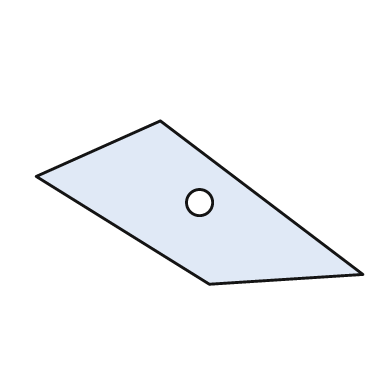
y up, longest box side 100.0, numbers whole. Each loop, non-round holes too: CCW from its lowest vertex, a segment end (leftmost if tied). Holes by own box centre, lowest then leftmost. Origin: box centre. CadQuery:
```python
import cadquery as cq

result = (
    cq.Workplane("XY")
    .moveTo(3.0, -25.0)
    .lineTo(50.0, -22.0)
    .lineTo(-12.0, 25.0)
    .lineTo(-50.0, 8.0)
    .close()
    .moveTo(0.0, 0.0)
    .circle(4.0)
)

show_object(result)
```